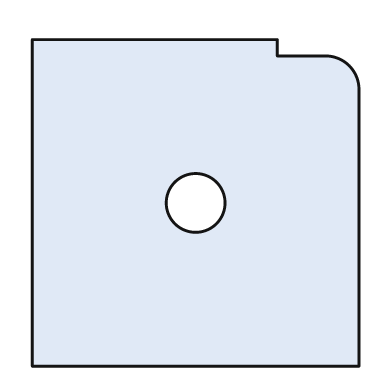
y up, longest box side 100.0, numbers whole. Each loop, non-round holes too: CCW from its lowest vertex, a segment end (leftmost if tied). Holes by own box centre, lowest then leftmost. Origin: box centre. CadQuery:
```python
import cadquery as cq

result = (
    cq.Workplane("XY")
    .moveTo(-50.0, -50.0)
    .lineTo(50.0, -50.0)
    .lineTo(50.0, 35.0)
    .threePointArc((47.0, 42.0), (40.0, 45.0))
    .lineTo(25.0, 45.0)
    .lineTo(25.0, 50.0)
    .lineTo(-50.0, 50.0)
    .close()
    .moveTo(0.0, 0.0)
    .circle(9.0)
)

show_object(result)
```